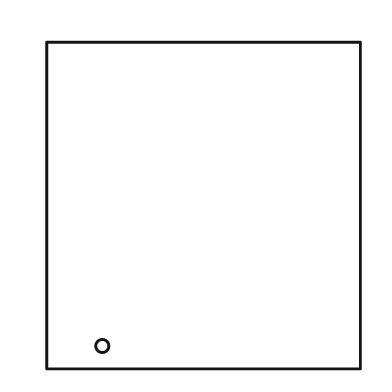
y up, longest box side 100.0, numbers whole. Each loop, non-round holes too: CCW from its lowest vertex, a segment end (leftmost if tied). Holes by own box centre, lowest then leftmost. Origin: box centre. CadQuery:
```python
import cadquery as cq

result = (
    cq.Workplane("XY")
    .moveTo(-48.0, -50.0)
    .lineTo(48.0, -50.0)
    .lineTo(48.0, 50.0)
    .lineTo(-48.0, 50.0)
    .close()
    .moveTo(-31.0, -43.0)
    .circle(2.0)
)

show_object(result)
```